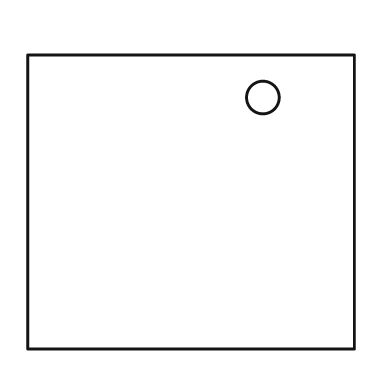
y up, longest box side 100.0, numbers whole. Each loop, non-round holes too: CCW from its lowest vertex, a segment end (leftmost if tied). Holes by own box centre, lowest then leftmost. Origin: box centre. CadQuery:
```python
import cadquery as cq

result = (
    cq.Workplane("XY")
    .moveTo(-50.0, -45.0)
    .lineTo(50.0, -45.0)
    .lineTo(50.0, 45.0)
    .lineTo(-50.0, 45.0)
    .close()
    .moveTo(22.0, 32.0)
    .circle(5.0)
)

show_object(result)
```